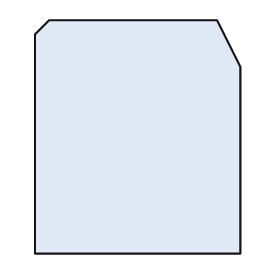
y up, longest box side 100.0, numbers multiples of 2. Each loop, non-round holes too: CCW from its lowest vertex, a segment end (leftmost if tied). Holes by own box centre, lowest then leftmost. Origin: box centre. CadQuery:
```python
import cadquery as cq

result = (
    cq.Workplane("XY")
    .moveTo(-44.0, -50.0)
    .lineTo(44.0, -50.0)
    .lineTo(44.0, 30.0)
    .lineTo(34.0, 50.0)
    .lineTo(-38.0, 50.0)
    .lineTo(-44.0, 44.0)
    .close()
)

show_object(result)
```